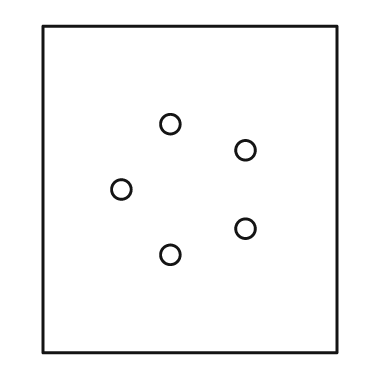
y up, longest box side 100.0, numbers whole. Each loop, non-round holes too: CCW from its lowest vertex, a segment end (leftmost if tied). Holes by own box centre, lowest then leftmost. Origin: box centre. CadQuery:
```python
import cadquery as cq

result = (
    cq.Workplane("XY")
    .moveTo(-45.0, -50.0)
    .lineTo(45.0, -50.0)
    .lineTo(45.0, 50.0)
    .lineTo(-45.0, 50.0)
    .close()
    .moveTo(-6.0, -20.0)
    .circle(3.0)
    .moveTo(17.0, -12.0)
    .circle(3.0)
    .moveTo(-21.0, 0.0)
    .circle(3.0)
    .moveTo(17.0, 12.0)
    .circle(3.0)
    .moveTo(-6.0, 20.0)
    .circle(3.0)
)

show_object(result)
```